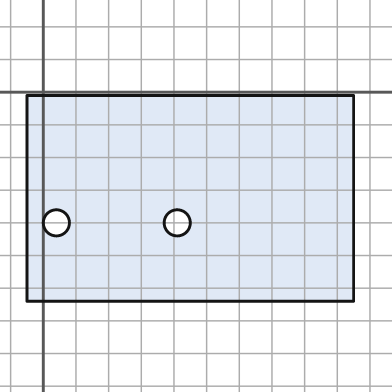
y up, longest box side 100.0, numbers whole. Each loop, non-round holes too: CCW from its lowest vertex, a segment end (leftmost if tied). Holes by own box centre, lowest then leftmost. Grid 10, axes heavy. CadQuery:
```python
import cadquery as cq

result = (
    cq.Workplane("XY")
    .moveTo(-5.0, -64.0)
    .lineTo(95.0, -64.0)
    .lineTo(95.0, -1.0)
    .lineTo(-5.0, -1.0)
    .close()
    .moveTo(4.0, -40.0)
    .circle(4.0)
    .moveTo(41.0, -40.0)
    .circle(4.0)
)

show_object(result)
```